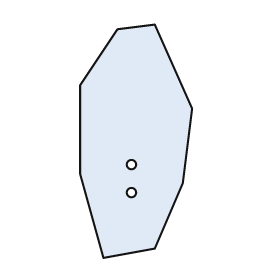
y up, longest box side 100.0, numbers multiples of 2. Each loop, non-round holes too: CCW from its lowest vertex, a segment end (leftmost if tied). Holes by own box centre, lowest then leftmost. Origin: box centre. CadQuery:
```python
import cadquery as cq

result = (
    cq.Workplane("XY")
    .moveTo(-14.0, -50.0)
    .lineTo(8.0, -46.0)
    .lineTo(20.0, -18.0)
    .lineTo(24.0, 14.0)
    .lineTo(8.0, 50.0)
    .lineTo(-8.0, 48.0)
    .lineTo(-24.0, 24.0)
    .lineTo(-24.0, -14.0)
    .close()
    .moveTo(-2.0, -22.0)
    .circle(2.0)
    .moveTo(-2.0, -10.0)
    .circle(2.0)
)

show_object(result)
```